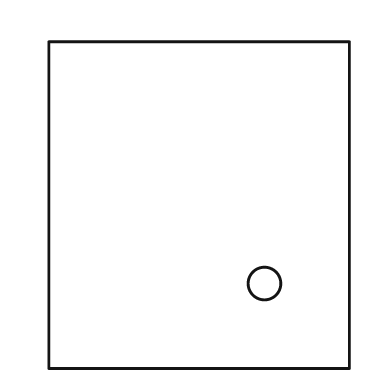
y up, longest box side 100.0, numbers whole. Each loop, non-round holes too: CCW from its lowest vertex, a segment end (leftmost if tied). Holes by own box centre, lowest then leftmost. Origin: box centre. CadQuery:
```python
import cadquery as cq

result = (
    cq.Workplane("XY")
    .moveTo(-46.0, -50.0)
    .lineTo(46.0, -50.0)
    .lineTo(46.0, 50.0)
    .lineTo(-46.0, 50.0)
    .close()
    .moveTo(20.0, -24.0)
    .circle(5.0)
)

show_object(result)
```